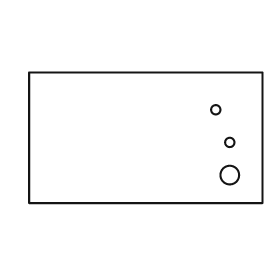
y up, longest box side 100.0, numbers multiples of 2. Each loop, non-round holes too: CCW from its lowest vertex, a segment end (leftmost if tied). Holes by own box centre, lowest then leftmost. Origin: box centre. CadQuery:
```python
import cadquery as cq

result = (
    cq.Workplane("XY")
    .moveTo(-50.0, -28.0)
    .lineTo(50.0, -28.0)
    .lineTo(50.0, 28.0)
    .lineTo(-50.0, 28.0)
    .close()
    .moveTo(36.0, -16.0)
    .circle(4.0)
    .moveTo(36.0, -2.0)
    .circle(2.0)
    .moveTo(30.0, 12.0)
    .circle(2.0)
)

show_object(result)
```